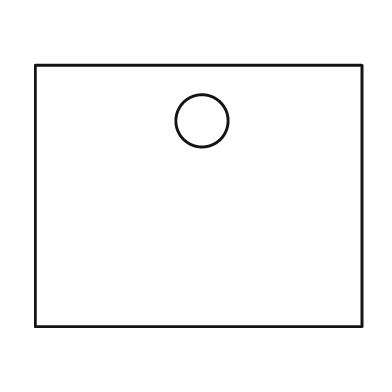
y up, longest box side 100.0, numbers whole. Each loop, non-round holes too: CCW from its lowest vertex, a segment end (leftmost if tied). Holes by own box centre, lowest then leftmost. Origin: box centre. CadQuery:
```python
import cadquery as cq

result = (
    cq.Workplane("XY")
    .moveTo(-50.0, -40.0)
    .lineTo(50.0, -40.0)
    .lineTo(50.0, 40.0)
    .lineTo(-50.0, 40.0)
    .close()
    .moveTo(1.0, 23.0)
    .circle(8.0)
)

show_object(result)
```